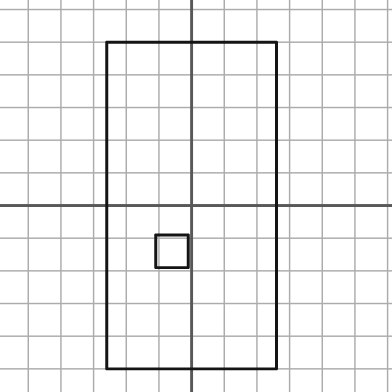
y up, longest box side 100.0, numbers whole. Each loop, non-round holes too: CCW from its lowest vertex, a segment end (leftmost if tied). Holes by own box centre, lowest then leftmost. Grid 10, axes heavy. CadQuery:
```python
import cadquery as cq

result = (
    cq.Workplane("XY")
    .moveTo(-26.0, -50.0)
    .lineTo(26.0, -50.0)
    .lineTo(26.0, 50.0)
    .lineTo(-26.0, 50.0)
    .close()
    .moveTo(-11.0, -19.0)
    .lineTo(-1.0, -19.0)
    .lineTo(-1.0, -9.0)
    .lineTo(-11.0, -9.0)
    .close()
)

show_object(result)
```